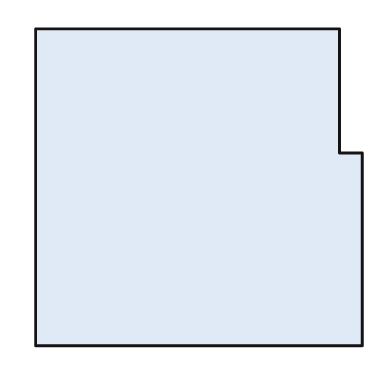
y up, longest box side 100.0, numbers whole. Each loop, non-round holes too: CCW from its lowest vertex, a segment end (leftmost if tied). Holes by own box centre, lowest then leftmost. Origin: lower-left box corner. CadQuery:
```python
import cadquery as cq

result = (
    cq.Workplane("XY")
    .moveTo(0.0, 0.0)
    .lineTo(100.0, 0.0)
    .lineTo(100.0, 59.0)
    .lineTo(93.0, 59.0)
    .lineTo(93.0, 97.0)
    .lineTo(0.0, 97.0)
    .close()
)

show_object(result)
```